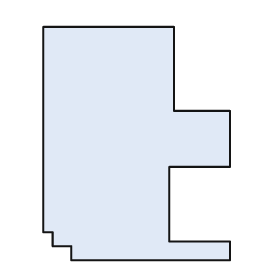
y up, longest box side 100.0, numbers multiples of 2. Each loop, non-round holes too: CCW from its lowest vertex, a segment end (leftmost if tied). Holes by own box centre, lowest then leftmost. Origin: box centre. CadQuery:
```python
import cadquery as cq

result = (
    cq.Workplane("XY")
    .moveTo(-28.0, -50.0)
    .lineTo(40.0, -50.0)
    .lineTo(40.0, -42.0)
    .lineTo(14.0, -42.0)
    .lineTo(14.0, -10.0)
    .lineTo(40.0, -10.0)
    .lineTo(40.0, 14.0)
    .lineTo(16.0, 14.0)
    .lineTo(16.0, 50.0)
    .lineTo(-40.0, 50.0)
    .lineTo(-40.0, -38.0)
    .lineTo(-36.0, -38.0)
    .lineTo(-36.0, -44.0)
    .lineTo(-28.0, -44.0)
    .close()
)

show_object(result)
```